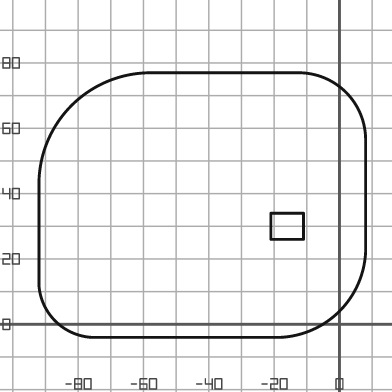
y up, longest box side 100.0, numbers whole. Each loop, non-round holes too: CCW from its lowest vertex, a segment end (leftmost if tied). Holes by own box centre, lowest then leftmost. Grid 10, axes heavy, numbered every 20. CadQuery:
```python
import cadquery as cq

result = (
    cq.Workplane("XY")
    .moveTo(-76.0, -4.0)
    .lineTo(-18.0, -4.0)
    .threePointArc((0.0, 4.0), (8.0, 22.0))
    .lineTo(8.0, 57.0)
    .threePointArc((2.0, 71.0), (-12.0, 77.0))
    .lineTo(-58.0, 77.0)
    .threePointArc((-82.0, 67.0), (-92.0, 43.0))
    .lineTo(-92.0, 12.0)
    .threePointArc((-87.0, 1.0), (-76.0, -4.0))
    .close()
    .moveTo(-21.0, 26.0)
    .lineTo(-11.0, 26.0)
    .lineTo(-11.0, 34.0)
    .lineTo(-21.0, 34.0)
    .close()
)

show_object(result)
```